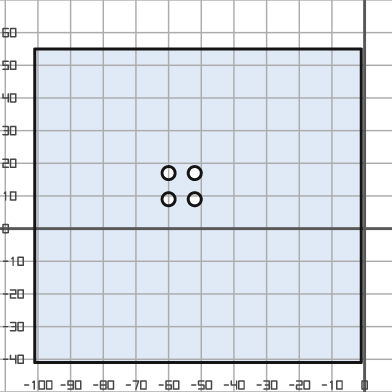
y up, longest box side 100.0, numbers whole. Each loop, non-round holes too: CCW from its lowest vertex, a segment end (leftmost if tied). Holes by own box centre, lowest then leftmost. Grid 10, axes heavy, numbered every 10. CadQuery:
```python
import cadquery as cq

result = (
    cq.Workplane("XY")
    .moveTo(-101.0, -41.0)
    .lineTo(-1.0, -41.0)
    .lineTo(-1.0, 55.0)
    .lineTo(-101.0, 55.0)
    .close()
    .moveTo(-60.0, 9.0)
    .circle(2.0)
    .moveTo(-52.0, 9.0)
    .circle(2.0)
    .moveTo(-60.0, 17.0)
    .circle(2.0)
    .moveTo(-52.0, 17.0)
    .circle(2.0)
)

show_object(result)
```